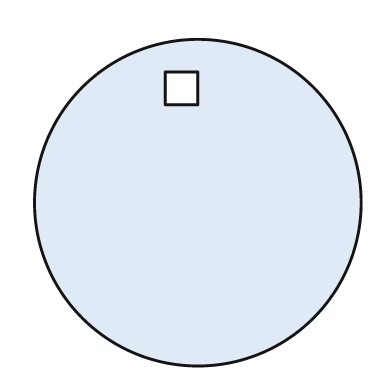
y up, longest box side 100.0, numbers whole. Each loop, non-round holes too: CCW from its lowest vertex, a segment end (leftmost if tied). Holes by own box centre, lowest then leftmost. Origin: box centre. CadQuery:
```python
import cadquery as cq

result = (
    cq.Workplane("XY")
    .moveTo(0.0, 0.0)
    .circle(50.0)
    .moveTo(-10.0, 30.0)
    .lineTo(0.0, 30.0)
    .lineTo(0.0, 40.0)
    .lineTo(-10.0, 40.0)
    .close()
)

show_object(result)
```